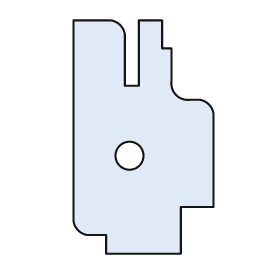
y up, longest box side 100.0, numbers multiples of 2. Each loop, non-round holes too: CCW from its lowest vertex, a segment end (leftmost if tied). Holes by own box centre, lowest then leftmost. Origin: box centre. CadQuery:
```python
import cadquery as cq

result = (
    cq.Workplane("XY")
    .moveTo(-16.0, -50.0)
    .lineTo(16.0, -50.0)
    .lineTo(16.0, -30.0)
    .lineTo(30.0, -30.0)
    .lineTo(30.0, 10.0)
    .threePointArc((28.0, 14.0), (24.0, 16.0))
    .lineTo(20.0, 16.0)
    .threePointArc((14.0, 18.0), (12.0, 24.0))
    .lineTo(12.0, 38.0)
    .lineTo(8.0, 38.0)
    .lineTo(8.0, 50.0)
    .lineTo(-2.0, 50.0)
    .lineTo(-2.0, 22.0)
    .lineTo(-8.0, 22.0)
    .lineTo(-8.0, 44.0)
    .threePointArc((-10.0, 48.0), (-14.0, 50.0))
    .lineTo(-30.0, 50.0)
    .lineTo(-30.0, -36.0)
    .threePointArc((-28.0, -40.0), (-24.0, -42.0))
    .lineTo(-16.0, -42.0)
    .close()
    .moveTo(-6.0, -8.0)
    .circle(6.0)
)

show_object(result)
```